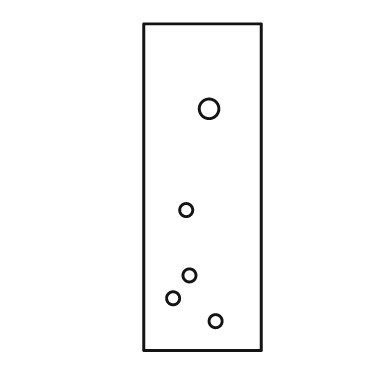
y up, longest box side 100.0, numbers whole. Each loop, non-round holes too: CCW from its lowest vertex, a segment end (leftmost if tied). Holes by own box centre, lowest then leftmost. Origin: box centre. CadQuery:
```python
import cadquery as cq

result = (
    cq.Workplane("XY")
    .moveTo(-18.0, -50.0)
    .lineTo(18.0, -50.0)
    .lineTo(18.0, 50.0)
    .lineTo(-18.0, 50.0)
    .close()
    .moveTo(4.0, -41.0)
    .circle(2.0)
    .moveTo(-9.0, -34.0)
    .circle(2.0)
    .moveTo(-4.0, -27.0)
    .circle(2.0)
    .moveTo(-5.0, -7.0)
    .circle(2.0)
    .moveTo(2.0, 24.0)
    .circle(3.0)
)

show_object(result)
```